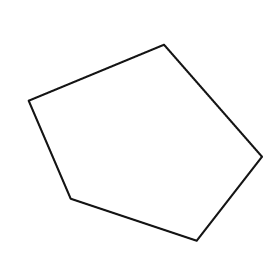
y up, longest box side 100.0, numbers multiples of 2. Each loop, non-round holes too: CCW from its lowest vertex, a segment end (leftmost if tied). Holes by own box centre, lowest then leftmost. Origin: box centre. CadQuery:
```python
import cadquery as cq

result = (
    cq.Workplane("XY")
    .moveTo(22.0, -42.0)
    .lineTo(50.0, -6.0)
    .lineTo(8.0, 42.0)
    .lineTo(-50.0, 18.0)
    .lineTo(-32.0, -24.0)
    .close()
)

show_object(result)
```